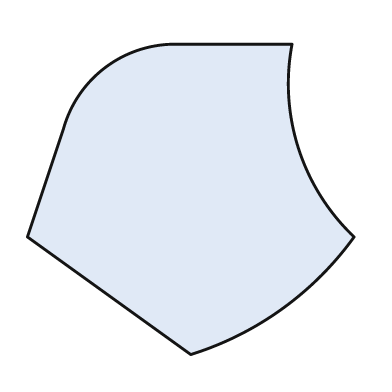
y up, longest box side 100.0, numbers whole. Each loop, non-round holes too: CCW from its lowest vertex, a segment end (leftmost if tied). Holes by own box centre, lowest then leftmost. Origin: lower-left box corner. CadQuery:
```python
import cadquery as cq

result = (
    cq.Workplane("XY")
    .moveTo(50.0, 0.0)
    .threePointArc((78.0, 14.0), (100.0, 36.0))
    .threePointArc((83.0, 63.0), (81.0, 95.0))
    .lineTo(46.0, 95.0)
    .threePointArc((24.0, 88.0), (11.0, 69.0))
    .lineTo(0.0, 36.0)
    .close()
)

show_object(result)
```